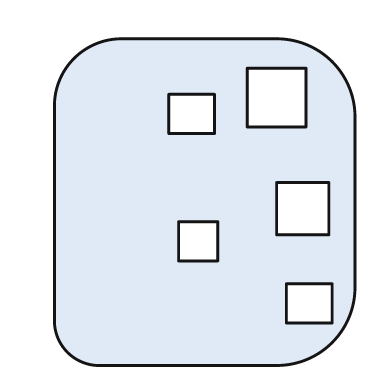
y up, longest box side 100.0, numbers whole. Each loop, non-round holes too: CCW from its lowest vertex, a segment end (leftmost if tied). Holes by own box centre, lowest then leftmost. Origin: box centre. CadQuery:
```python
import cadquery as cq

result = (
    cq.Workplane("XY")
    .moveTo(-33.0, -50.0)
    .lineTo(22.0, -50.0)
    .threePointArc((39.0, -43.0), (46.0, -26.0))
    .lineTo(46.0, 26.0)
    .threePointArc((39.0, 43.0), (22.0, 50.0))
    .lineTo(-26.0, 50.0)
    .threePointArc((-40.0, 44.0), (-46.0, 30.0))
    .lineTo(-46.0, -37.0)
    .threePointArc((-42.0, -46.0), (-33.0, -50.0))
    .close()
    .moveTo(25.0, -37.0)
    .lineTo(39.0, -37.0)
    .lineTo(39.0, -25.0)
    .lineTo(25.0, -25.0)
    .close()
    .moveTo(-8.0, -18.0)
    .lineTo(4.0, -18.0)
    .lineTo(4.0, -6.0)
    .lineTo(-8.0, -6.0)
    .close()
    .moveTo(22.0, -10.0)
    .lineTo(38.0, -10.0)
    .lineTo(38.0, 6.0)
    .lineTo(22.0, 6.0)
    .close()
    .moveTo(-11.0, 21.0)
    .lineTo(3.0, 21.0)
    .lineTo(3.0, 33.0)
    .lineTo(-11.0, 33.0)
    .close()
    .moveTo(13.0, 23.0)
    .lineTo(31.0, 23.0)
    .lineTo(31.0, 41.0)
    .lineTo(13.0, 41.0)
    .close()
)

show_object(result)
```